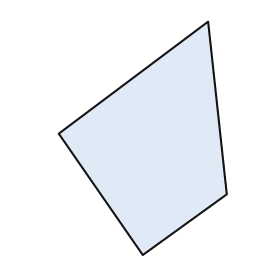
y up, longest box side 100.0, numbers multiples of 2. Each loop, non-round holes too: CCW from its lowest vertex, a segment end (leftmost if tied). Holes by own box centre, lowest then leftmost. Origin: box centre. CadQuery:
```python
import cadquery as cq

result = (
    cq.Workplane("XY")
    .moveTo(0.0, -50.0)
    .lineTo(36.0, -24.0)
    .lineTo(28.0, 50.0)
    .lineTo(-36.0, 2.0)
    .close()
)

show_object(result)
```